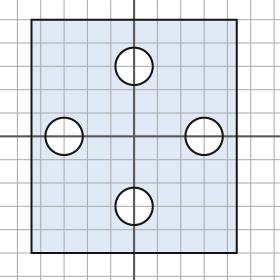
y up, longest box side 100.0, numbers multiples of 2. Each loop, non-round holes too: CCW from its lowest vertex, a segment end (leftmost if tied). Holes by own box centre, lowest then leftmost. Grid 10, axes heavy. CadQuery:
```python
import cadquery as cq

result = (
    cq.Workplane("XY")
    .moveTo(-44.0, -50.0)
    .lineTo(44.0, -50.0)
    .lineTo(44.0, 50.0)
    .lineTo(-44.0, 50.0)
    .close()
    .moveTo(0.0, -30.0)
    .circle(8.0)
    .moveTo(-30.0, 0.0)
    .circle(8.0)
    .moveTo(30.0, 0.0)
    .circle(8.0)
    .moveTo(0.0, 30.0)
    .circle(8.0)
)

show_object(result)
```